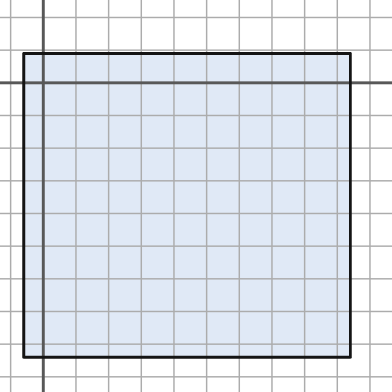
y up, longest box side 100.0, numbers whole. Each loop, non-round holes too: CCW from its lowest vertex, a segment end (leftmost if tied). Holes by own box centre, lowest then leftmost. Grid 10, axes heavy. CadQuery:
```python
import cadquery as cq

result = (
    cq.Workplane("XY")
    .moveTo(-6.0, -84.0)
    .lineTo(94.0, -84.0)
    .lineTo(94.0, 9.0)
    .lineTo(-6.0, 9.0)
    .close()
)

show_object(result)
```